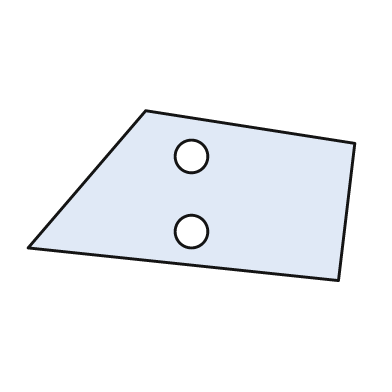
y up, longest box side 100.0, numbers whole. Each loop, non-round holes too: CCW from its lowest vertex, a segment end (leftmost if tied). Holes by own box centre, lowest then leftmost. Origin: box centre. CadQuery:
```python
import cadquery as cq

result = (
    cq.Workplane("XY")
    .moveTo(45.0, -26.0)
    .lineTo(50.0, 16.0)
    .lineTo(-14.0, 26.0)
    .lineTo(-50.0, -16.0)
    .close()
    .moveTo(0.0, -11.0)
    .circle(5.0)
    .moveTo(0.0, 12.0)
    .circle(5.0)
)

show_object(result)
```